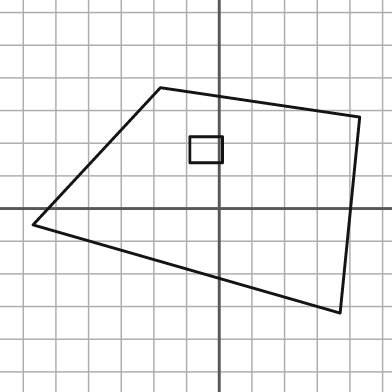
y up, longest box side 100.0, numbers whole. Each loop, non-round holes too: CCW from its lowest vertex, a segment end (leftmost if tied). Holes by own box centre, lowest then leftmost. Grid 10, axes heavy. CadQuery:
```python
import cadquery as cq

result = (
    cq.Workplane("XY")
    .moveTo(37.0, -32.0)
    .lineTo(43.0, 28.0)
    .lineTo(-18.0, 37.0)
    .lineTo(-57.0, -5.0)
    .close()
    .moveTo(-9.0, 14.0)
    .lineTo(1.0, 14.0)
    .lineTo(1.0, 22.0)
    .lineTo(-9.0, 22.0)
    .close()
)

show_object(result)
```